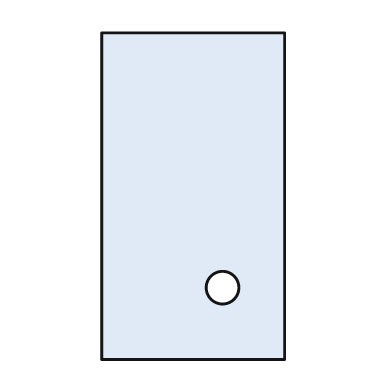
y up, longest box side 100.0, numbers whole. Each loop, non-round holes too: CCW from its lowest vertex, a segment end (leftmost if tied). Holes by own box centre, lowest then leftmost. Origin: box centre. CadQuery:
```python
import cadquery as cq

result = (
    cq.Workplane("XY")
    .moveTo(-28.0, -50.0)
    .lineTo(28.0, -50.0)
    .lineTo(28.0, 50.0)
    .lineTo(-28.0, 50.0)
    .close()
    .moveTo(9.0, -28.0)
    .circle(5.0)
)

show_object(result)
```